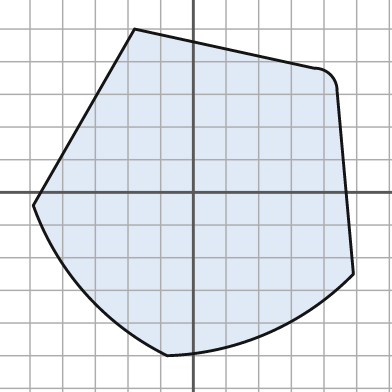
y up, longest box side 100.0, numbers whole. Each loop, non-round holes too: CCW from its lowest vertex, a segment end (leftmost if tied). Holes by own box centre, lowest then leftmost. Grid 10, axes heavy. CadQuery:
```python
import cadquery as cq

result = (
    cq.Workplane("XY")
    .moveTo(-8.0, -50.0)
    .threePointArc((23.0, -43.0), (49.0, -25.0))
    .lineTo(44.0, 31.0)
    .threePointArc((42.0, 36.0), (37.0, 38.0))
    .lineTo(-18.0, 50.0)
    .lineTo(-49.0, -4.0)
    .threePointArc((-33.0, -31.0), (-8.0, -50.0))
    .close()
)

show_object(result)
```